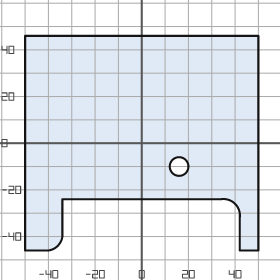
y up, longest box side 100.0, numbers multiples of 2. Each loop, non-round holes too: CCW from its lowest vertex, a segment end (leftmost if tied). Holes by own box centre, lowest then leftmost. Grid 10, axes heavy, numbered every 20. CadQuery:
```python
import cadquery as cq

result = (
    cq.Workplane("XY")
    .moveTo(-50.0, -46.0)
    .lineTo(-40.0, -46.0)
    .threePointArc((-36.0, -44.0), (-34.0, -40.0))
    .lineTo(-34.0, -24.0)
    .lineTo(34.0, -24.0)
    .threePointArc((40.0, -26.0), (42.0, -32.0))
    .lineTo(42.0, -46.0)
    .lineTo(50.0, -46.0)
    .lineTo(50.0, 46.0)
    .lineTo(-50.0, 46.0)
    .close()
    .moveTo(16.0, -10.0)
    .circle(4.0)
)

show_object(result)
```